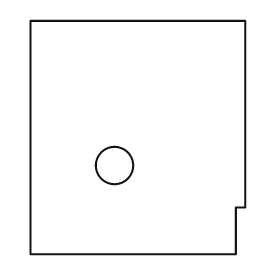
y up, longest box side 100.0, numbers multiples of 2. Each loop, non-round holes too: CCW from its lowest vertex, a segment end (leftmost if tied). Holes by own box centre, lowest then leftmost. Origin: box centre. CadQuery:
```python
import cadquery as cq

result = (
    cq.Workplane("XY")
    .moveTo(-46.0, -50.0)
    .lineTo(42.0, -50.0)
    .lineTo(42.0, -30.0)
    .lineTo(46.0, -30.0)
    .lineTo(46.0, 50.0)
    .lineTo(-46.0, 50.0)
    .close()
    .moveTo(-10.0, -12.0)
    .circle(8.0)
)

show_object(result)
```